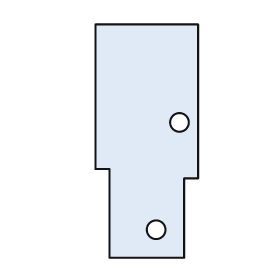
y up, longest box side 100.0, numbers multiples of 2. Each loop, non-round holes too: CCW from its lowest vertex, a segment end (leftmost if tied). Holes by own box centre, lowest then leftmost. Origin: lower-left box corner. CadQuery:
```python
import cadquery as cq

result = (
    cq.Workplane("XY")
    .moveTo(6.0, 0.0)
    .lineTo(38.0, 0.0)
    .lineTo(38.0, 34.0)
    .lineTo(44.0, 34.0)
    .lineTo(44.0, 100.0)
    .lineTo(0.0, 100.0)
    .lineTo(0.0, 38.0)
    .lineTo(6.0, 38.0)
    .close()
    .moveTo(26.0, 12.0)
    .circle(4.0)
    .moveTo(36.0, 58.0)
    .circle(4.0)
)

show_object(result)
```